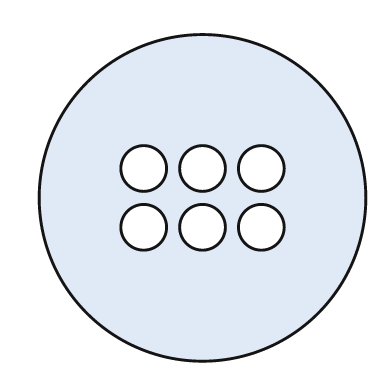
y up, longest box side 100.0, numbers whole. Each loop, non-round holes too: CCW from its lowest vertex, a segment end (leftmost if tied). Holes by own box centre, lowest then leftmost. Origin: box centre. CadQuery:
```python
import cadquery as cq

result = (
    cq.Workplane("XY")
    .moveTo(0.0, 0.0)
    .circle(50.0)
    .moveTo(-18.0, -9.0)
    .circle(7.0)
    .moveTo(0.0, -9.0)
    .circle(7.0)
    .moveTo(18.0, -9.0)
    .circle(7.0)
    .moveTo(-18.0, 9.0)
    .circle(7.0)
    .moveTo(0.0, 9.0)
    .circle(7.0)
    .moveTo(18.0, 9.0)
    .circle(7.0)
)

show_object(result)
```